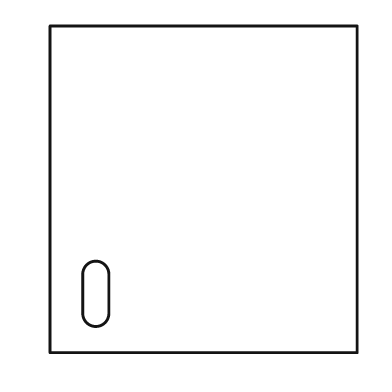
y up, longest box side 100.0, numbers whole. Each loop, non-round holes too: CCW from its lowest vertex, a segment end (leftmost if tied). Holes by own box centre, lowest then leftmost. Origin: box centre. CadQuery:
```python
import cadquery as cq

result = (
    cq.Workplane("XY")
    .moveTo(-47.0, -50.0)
    .lineTo(47.0, -50.0)
    .lineTo(47.0, 50.0)
    .lineTo(-47.0, 50.0)
    .close()
    .moveTo(-37.0, -38.0)
    .threePointArc((-33.0, -42.0), (-29.0, -38.0))
    .lineTo(-29.0, -26.0)
    .threePointArc((-33.0, -22.0), (-37.0, -26.0))
    .close()
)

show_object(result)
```